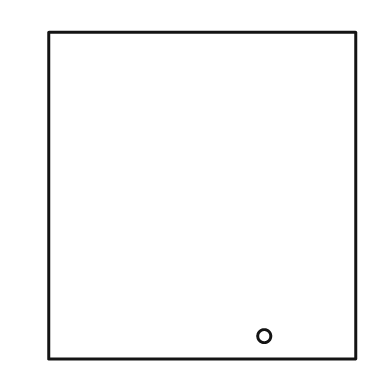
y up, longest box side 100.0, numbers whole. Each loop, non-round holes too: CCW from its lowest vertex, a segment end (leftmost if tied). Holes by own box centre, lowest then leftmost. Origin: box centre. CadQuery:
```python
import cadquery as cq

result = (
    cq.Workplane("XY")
    .moveTo(-47.0, -50.0)
    .lineTo(47.0, -50.0)
    .lineTo(47.0, 50.0)
    .lineTo(-47.0, 50.0)
    .close()
    .moveTo(19.0, -43.0)
    .circle(2.0)
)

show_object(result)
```